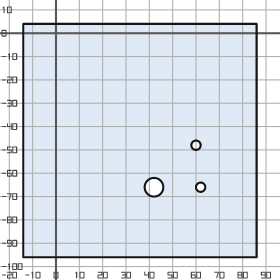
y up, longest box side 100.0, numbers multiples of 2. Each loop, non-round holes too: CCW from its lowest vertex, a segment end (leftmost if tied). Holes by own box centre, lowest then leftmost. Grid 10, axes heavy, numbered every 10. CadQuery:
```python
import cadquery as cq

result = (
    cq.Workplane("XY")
    .moveTo(-14.0, -96.0)
    .lineTo(86.0, -96.0)
    .lineTo(86.0, 4.0)
    .lineTo(-14.0, 4.0)
    .close()
    .moveTo(42.0, -66.0)
    .circle(4.0)
    .moveTo(62.0, -66.0)
    .circle(2.0)
    .moveTo(60.0, -48.0)
    .circle(2.0)
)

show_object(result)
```